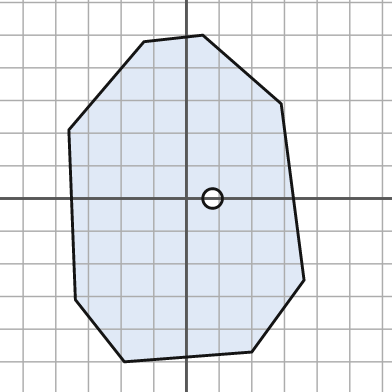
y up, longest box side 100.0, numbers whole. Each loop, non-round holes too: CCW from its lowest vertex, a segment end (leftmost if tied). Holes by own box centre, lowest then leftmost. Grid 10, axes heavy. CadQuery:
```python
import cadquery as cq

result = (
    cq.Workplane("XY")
    .moveTo(-19.0, -50.0)
    .lineTo(20.0, -47.0)
    .lineTo(36.0, -25.0)
    .lineTo(29.0, 29.0)
    .lineTo(5.0, 50.0)
    .lineTo(-13.0, 48.0)
    .lineTo(-36.0, 21.0)
    .lineTo(-34.0, -31.0)
    .close()
    .moveTo(8.0, 0.0)
    .circle(3.0)
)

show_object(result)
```